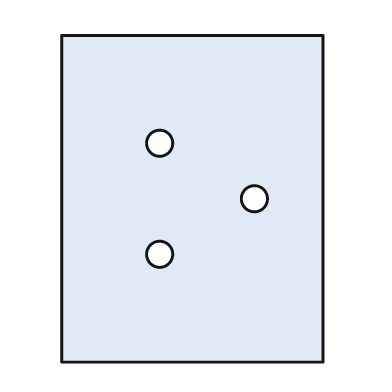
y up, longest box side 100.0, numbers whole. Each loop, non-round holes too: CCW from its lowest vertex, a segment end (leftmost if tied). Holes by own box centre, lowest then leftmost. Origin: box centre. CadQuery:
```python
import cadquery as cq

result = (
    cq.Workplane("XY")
    .moveTo(-40.0, -50.0)
    .lineTo(40.0, -50.0)
    .lineTo(40.0, 50.0)
    .lineTo(-40.0, 50.0)
    .close()
    .moveTo(-10.0, -17.0)
    .circle(4.0)
    .moveTo(19.0, 0.0)
    .circle(4.0)
    .moveTo(-10.0, 17.0)
    .circle(4.0)
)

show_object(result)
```